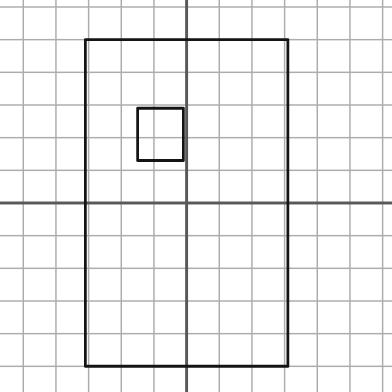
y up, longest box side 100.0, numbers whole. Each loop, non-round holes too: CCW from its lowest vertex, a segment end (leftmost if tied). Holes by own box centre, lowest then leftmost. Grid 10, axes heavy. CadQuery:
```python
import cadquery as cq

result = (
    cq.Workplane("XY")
    .moveTo(-31.0, -50.0)
    .lineTo(31.0, -50.0)
    .lineTo(31.0, 50.0)
    .lineTo(-31.0, 50.0)
    .close()
    .moveTo(-15.0, 13.0)
    .lineTo(-1.0, 13.0)
    .lineTo(-1.0, 29.0)
    .lineTo(-15.0, 29.0)
    .close()
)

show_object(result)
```